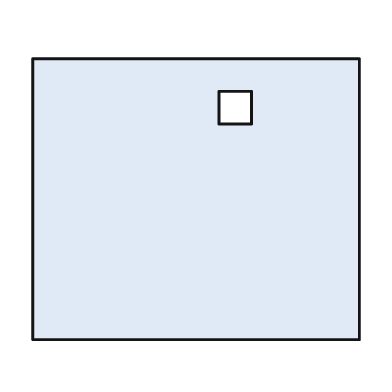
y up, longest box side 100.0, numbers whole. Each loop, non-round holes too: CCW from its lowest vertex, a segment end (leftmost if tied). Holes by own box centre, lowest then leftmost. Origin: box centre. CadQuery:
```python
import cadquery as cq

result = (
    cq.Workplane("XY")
    .moveTo(-50.0, -43.0)
    .lineTo(50.0, -43.0)
    .lineTo(50.0, 43.0)
    .lineTo(-50.0, 43.0)
    .close()
    .moveTo(7.0, 23.0)
    .lineTo(17.0, 23.0)
    .lineTo(17.0, 33.0)
    .lineTo(7.0, 33.0)
    .close()
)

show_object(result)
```